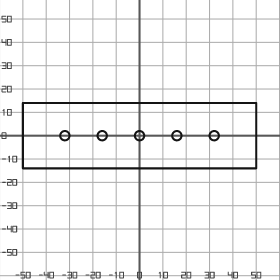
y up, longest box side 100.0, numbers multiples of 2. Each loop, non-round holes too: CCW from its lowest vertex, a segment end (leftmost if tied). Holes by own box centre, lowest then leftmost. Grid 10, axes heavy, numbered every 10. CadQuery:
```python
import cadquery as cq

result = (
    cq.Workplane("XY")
    .moveTo(-50.0, -14.0)
    .lineTo(50.0, -14.0)
    .lineTo(50.0, 14.0)
    .lineTo(-50.0, 14.0)
    .close()
    .moveTo(-32.0, 0.0)
    .circle(2.0)
    .moveTo(-16.0, 0.0)
    .circle(2.0)
    .moveTo(0.0, 0.0)
    .circle(2.0)
    .moveTo(16.0, 0.0)
    .circle(2.0)
    .moveTo(32.0, 0.0)
    .circle(2.0)
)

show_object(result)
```